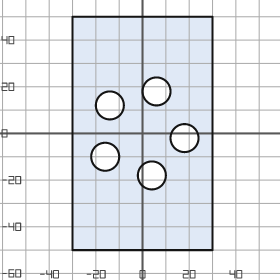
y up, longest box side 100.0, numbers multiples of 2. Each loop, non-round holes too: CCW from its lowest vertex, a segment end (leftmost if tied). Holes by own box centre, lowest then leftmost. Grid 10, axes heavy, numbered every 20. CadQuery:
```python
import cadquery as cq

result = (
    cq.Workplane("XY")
    .moveTo(-30.0, -50.0)
    .lineTo(30.0, -50.0)
    .lineTo(30.0, 50.0)
    .lineTo(-30.0, 50.0)
    .close()
    .moveTo(4.0, -18.0)
    .circle(6.0)
    .moveTo(-16.0, -10.0)
    .circle(6.0)
    .moveTo(18.0, -2.0)
    .circle(6.0)
    .moveTo(-14.0, 12.0)
    .circle(6.0)
    .moveTo(6.0, 18.0)
    .circle(6.0)
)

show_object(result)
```